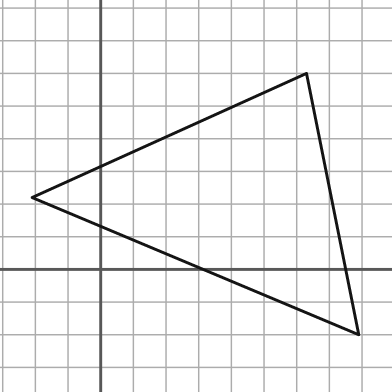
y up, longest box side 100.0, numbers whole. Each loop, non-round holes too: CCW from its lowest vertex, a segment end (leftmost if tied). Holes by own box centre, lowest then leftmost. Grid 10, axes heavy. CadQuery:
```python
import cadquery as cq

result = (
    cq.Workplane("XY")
    .moveTo(79.0, -20.0)
    .lineTo(63.0, 60.0)
    .lineTo(-21.0, 22.0)
    .close()
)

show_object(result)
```